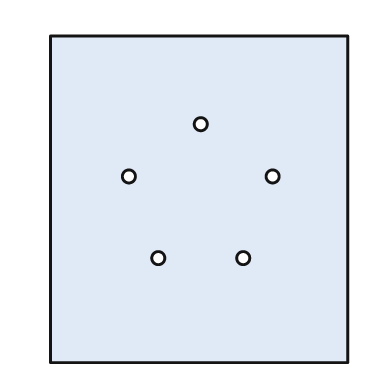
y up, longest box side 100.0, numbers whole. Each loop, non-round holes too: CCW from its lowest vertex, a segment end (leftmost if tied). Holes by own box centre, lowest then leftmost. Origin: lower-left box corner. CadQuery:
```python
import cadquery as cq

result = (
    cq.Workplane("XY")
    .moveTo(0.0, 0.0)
    .lineTo(91.0, 0.0)
    .lineTo(91.0, 100.0)
    .lineTo(0.0, 100.0)
    .close()
    .moveTo(33.0, 32.0)
    .circle(2.0)
    .moveTo(59.0, 32.0)
    .circle(2.0)
    .moveTo(24.0, 57.0)
    .circle(2.0)
    .moveTo(68.0, 57.0)
    .circle(2.0)
    .moveTo(46.0, 73.0)
    .circle(2.0)
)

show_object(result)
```